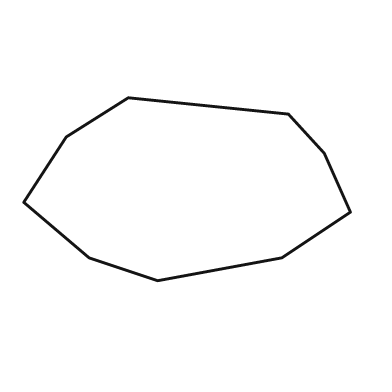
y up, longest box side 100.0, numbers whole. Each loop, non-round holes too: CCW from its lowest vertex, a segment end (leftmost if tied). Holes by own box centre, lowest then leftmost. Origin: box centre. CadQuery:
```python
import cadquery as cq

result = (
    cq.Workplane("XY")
    .moveTo(-9.0, -28.0)
    .lineTo(29.0, -21.0)
    .lineTo(50.0, -7.0)
    .lineTo(42.0, 11.0)
    .lineTo(31.0, 23.0)
    .lineTo(-18.0, 28.0)
    .lineTo(-37.0, 16.0)
    .lineTo(-50.0, -4.0)
    .lineTo(-30.0, -21.0)
    .close()
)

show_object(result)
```